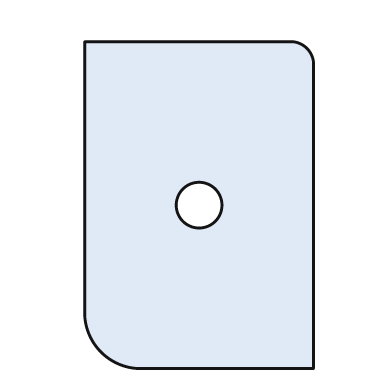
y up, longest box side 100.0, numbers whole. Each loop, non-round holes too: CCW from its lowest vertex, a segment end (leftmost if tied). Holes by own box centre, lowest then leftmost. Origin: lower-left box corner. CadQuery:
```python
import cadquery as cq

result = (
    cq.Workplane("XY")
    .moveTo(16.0, 0.0)
    .lineTo(70.0, 0.0)
    .lineTo(70.0, 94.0)
    .threePointArc((68.0, 98.0), (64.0, 100.0))
    .lineTo(0.0, 100.0)
    .lineTo(0.0, 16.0)
    .threePointArc((5.0, 5.0), (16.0, 0.0))
    .close()
    .moveTo(35.0, 50.0)
    .circle(7.0)
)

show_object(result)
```